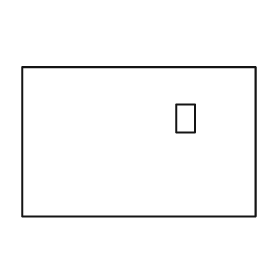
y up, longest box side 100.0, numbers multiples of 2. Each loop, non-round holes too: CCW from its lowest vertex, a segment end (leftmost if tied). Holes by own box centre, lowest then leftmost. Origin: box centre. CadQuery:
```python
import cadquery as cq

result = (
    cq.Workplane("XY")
    .moveTo(-50.0, -32.0)
    .lineTo(50.0, -32.0)
    .lineTo(50.0, 32.0)
    .lineTo(-50.0, 32.0)
    .close()
    .moveTo(16.0, 4.0)
    .lineTo(24.0, 4.0)
    .lineTo(24.0, 16.0)
    .lineTo(16.0, 16.0)
    .close()
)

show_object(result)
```